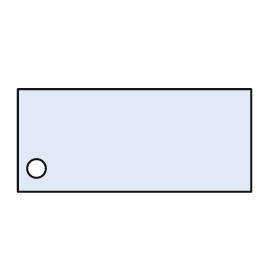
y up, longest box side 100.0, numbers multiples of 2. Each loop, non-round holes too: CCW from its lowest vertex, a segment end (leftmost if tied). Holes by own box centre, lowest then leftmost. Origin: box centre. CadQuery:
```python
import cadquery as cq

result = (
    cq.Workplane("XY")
    .moveTo(-50.0, -22.0)
    .lineTo(50.0, -22.0)
    .lineTo(50.0, 22.0)
    .lineTo(-50.0, 22.0)
    .close()
    .moveTo(-42.0, -12.0)
    .circle(4.0)
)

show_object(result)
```